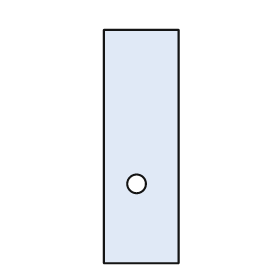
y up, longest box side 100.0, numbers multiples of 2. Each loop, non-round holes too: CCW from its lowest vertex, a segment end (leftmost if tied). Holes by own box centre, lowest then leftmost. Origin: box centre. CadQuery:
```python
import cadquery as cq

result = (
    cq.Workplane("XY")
    .moveTo(-16.0, -50.0)
    .lineTo(16.0, -50.0)
    .lineTo(16.0, 50.0)
    .lineTo(-16.0, 50.0)
    .close()
    .moveTo(-2.0, -16.0)
    .circle(4.0)
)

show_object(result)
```